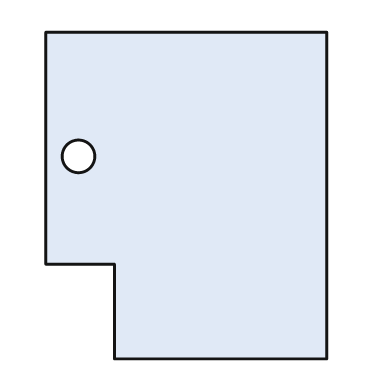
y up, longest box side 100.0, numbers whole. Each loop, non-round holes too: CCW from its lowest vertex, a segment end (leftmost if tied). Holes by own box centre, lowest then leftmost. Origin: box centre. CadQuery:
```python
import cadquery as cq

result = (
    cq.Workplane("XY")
    .moveTo(-22.0, -50.0)
    .lineTo(43.0, -50.0)
    .lineTo(43.0, 50.0)
    .lineTo(-43.0, 50.0)
    .lineTo(-43.0, -21.0)
    .lineTo(-22.0, -21.0)
    .close()
    .moveTo(-33.0, 12.0)
    .circle(5.0)
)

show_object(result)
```